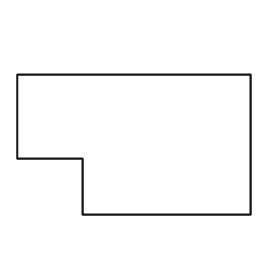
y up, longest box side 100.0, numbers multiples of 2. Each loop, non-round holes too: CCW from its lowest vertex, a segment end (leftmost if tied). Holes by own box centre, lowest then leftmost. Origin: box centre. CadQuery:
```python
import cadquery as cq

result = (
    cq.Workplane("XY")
    .moveTo(-22.0, -30.0)
    .lineTo(50.0, -30.0)
    .lineTo(50.0, 30.0)
    .lineTo(-50.0, 30.0)
    .lineTo(-50.0, -6.0)
    .lineTo(-22.0, -6.0)
    .close()
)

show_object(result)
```